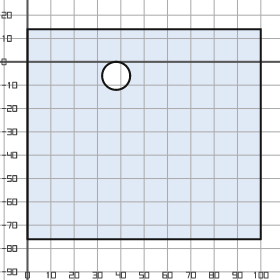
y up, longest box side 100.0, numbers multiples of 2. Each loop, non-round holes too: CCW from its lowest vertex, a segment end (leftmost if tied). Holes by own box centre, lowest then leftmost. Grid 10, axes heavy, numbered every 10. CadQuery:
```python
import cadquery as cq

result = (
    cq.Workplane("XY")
    .moveTo(0.0, -76.0)
    .lineTo(100.0, -76.0)
    .lineTo(100.0, 14.0)
    .lineTo(0.0, 14.0)
    .close()
    .moveTo(38.0, -6.0)
    .circle(6.0)
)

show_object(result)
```